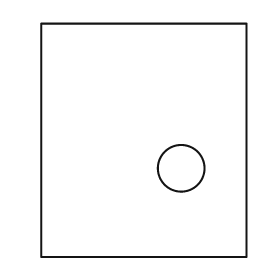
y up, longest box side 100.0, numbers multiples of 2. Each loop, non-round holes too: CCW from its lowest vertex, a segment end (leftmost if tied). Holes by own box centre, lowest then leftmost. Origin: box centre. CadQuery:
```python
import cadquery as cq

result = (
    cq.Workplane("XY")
    .moveTo(-44.0, -50.0)
    .lineTo(44.0, -50.0)
    .lineTo(44.0, 50.0)
    .lineTo(-44.0, 50.0)
    .close()
    .moveTo(16.0, -12.0)
    .circle(10.0)
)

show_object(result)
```